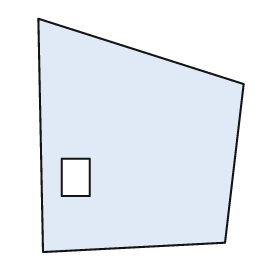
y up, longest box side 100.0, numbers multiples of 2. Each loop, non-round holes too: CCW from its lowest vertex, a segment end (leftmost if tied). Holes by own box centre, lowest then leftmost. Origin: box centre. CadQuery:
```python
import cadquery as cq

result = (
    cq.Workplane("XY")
    .moveTo(-42.0, -50.0)
    .lineTo(36.0, -46.0)
    .lineTo(44.0, 22.0)
    .lineTo(-44.0, 50.0)
    .close()
    .moveTo(-34.0, -26.0)
    .lineTo(-22.0, -26.0)
    .lineTo(-22.0, -10.0)
    .lineTo(-34.0, -10.0)
    .close()
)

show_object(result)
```